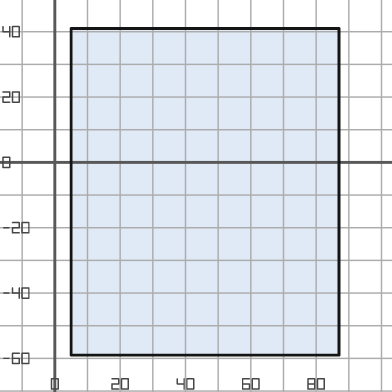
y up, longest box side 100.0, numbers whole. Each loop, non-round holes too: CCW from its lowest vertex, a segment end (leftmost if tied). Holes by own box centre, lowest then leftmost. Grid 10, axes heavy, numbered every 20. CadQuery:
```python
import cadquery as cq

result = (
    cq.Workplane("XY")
    .moveTo(5.0, -59.0)
    .lineTo(87.0, -59.0)
    .lineTo(87.0, 41.0)
    .lineTo(5.0, 41.0)
    .close()
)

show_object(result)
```